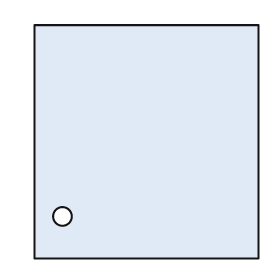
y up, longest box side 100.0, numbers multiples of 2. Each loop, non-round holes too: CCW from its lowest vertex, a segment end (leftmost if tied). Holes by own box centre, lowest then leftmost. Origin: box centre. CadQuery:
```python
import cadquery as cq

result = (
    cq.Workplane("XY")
    .moveTo(-48.0, -50.0)
    .lineTo(48.0, -50.0)
    .lineTo(48.0, 50.0)
    .lineTo(-48.0, 50.0)
    .close()
    .moveTo(-36.0, -32.0)
    .circle(4.0)
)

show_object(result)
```